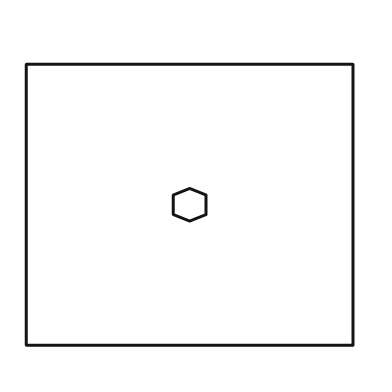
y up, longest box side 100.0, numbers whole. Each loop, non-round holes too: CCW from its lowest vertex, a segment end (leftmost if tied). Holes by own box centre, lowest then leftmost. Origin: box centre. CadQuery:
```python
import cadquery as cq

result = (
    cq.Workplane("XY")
    .moveTo(-50.0, -43.0)
    .lineTo(50.0, -43.0)
    .lineTo(50.0, 43.0)
    .lineTo(-50.0, 43.0)
    .close()
    .moveTo(0.0, -5.0)
    .lineTo(5.0, -3.0)
    .lineTo(5.0, 3.0)
    .lineTo(0.0, 5.0)
    .lineTo(-5.0, 3.0)
    .lineTo(-5.0, -3.0)
    .close()
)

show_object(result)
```